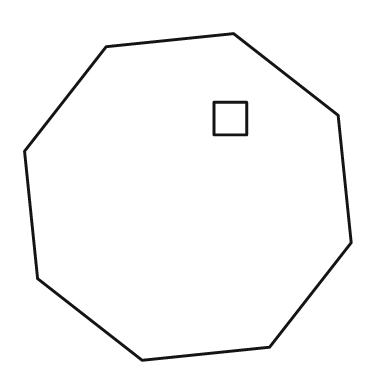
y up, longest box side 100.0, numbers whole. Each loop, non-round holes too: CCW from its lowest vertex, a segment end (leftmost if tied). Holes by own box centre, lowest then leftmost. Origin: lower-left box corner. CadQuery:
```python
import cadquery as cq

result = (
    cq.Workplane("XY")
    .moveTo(36.0, 0.0)
    .lineTo(75.0, 4.0)
    .lineTo(100.0, 36.0)
    .lineTo(96.0, 75.0)
    .lineTo(64.0, 100.0)
    .lineTo(25.0, 96.0)
    .lineTo(0.0, 64.0)
    .lineTo(4.0, 25.0)
    .close()
    .moveTo(58.0, 69.0)
    .lineTo(68.0, 69.0)
    .lineTo(68.0, 79.0)
    .lineTo(58.0, 79.0)
    .close()
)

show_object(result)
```